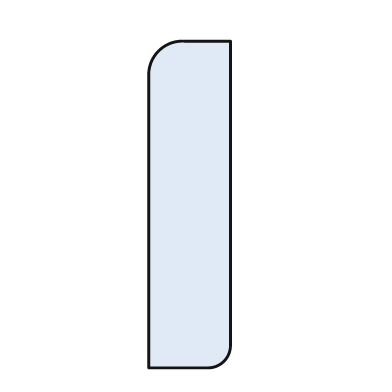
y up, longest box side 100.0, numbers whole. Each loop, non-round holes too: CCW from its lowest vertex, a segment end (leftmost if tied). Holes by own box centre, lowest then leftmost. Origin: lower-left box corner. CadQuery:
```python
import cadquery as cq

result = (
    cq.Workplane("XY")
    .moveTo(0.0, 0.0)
    .lineTo(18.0, 0.0)
    .threePointArc((23.0, 2.0), (25.0, 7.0))
    .lineTo(25.0, 100.0)
    .lineTo(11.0, 100.0)
    .threePointArc((3.0, 97.0), (0.0, 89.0))
    .close()
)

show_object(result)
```